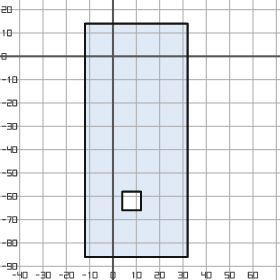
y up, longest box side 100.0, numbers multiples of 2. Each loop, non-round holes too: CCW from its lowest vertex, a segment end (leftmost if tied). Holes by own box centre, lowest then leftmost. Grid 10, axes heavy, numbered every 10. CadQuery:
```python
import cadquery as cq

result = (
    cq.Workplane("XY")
    .moveTo(-12.0, -86.0)
    .lineTo(32.0, -86.0)
    .lineTo(32.0, 14.0)
    .lineTo(-12.0, 14.0)
    .close()
    .moveTo(4.0, -66.0)
    .lineTo(12.0, -66.0)
    .lineTo(12.0, -58.0)
    .lineTo(4.0, -58.0)
    .close()
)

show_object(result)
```